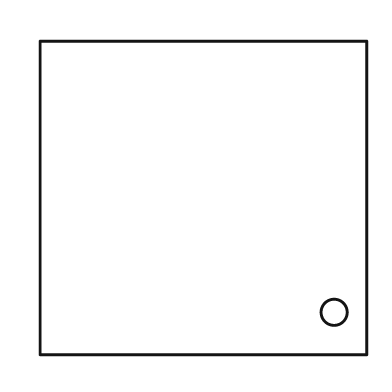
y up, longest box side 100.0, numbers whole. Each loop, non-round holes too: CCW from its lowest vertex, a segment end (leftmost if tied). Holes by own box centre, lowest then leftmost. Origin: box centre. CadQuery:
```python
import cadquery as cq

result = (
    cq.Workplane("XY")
    .moveTo(-50.0, -48.0)
    .lineTo(50.0, -48.0)
    .lineTo(50.0, 48.0)
    .lineTo(-50.0, 48.0)
    .close()
    .moveTo(40.0, -35.0)
    .circle(4.0)
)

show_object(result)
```